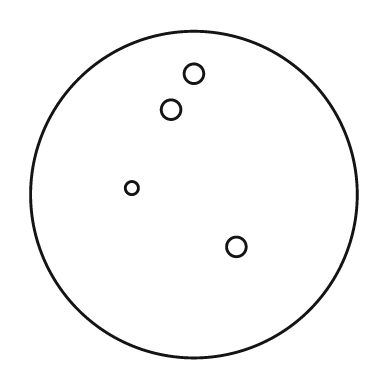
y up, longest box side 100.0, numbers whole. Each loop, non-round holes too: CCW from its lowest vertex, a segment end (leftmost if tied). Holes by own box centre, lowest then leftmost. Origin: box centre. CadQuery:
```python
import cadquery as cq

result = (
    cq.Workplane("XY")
    .moveTo(0.0, 0.0)
    .circle(50.0)
    .moveTo(13.0, -16.0)
    .circle(3.0)
    .moveTo(-19.0, 2.0)
    .circle(2.0)
    .moveTo(-7.0, 26.0)
    .circle(3.0)
    .moveTo(0.0, 37.0)
    .circle(3.0)
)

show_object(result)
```